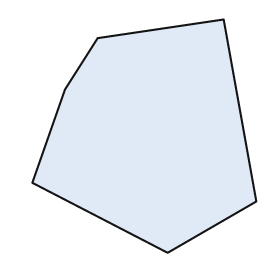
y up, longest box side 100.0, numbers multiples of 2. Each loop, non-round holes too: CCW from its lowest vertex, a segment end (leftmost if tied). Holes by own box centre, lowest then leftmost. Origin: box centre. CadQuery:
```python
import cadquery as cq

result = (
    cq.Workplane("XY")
    .moveTo(10.0, -50.0)
    .lineTo(48.0, -28.0)
    .lineTo(34.0, 50.0)
    .lineTo(-20.0, 42.0)
    .lineTo(-34.0, 20.0)
    .lineTo(-48.0, -20.0)
    .close()
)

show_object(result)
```